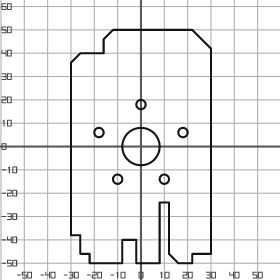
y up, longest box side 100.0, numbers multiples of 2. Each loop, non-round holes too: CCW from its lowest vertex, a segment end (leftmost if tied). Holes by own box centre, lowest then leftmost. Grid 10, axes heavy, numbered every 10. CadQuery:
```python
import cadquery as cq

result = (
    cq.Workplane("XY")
    .moveTo(-22.0, -50.0)
    .lineTo(-8.0, -50.0)
    .lineTo(-8.0, -40.0)
    .lineTo(-2.0, -40.0)
    .lineTo(-2.0, -50.0)
    .lineTo(8.0, -50.0)
    .lineTo(8.0, -24.0)
    .lineTo(12.0, -24.0)
    .lineTo(12.0, -46.0)
    .lineTo(16.0, -50.0)
    .lineTo(22.0, -50.0)
    .lineTo(22.0, -46.0)
    .lineTo(30.0, -46.0)
    .lineTo(30.0, 42.0)
    .lineTo(22.0, 50.0)
    .lineTo(-12.0, 50.0)
    .lineTo(-16.0, 46.0)
    .lineTo(-16.0, 40.0)
    .lineTo(-26.0, 40.0)
    .lineTo(-30.0, 36.0)
    .lineTo(-30.0, -38.0)
    .lineTo(-26.0, -38.0)
    .lineTo(-26.0, -46.0)
    .lineTo(-22.0, -46.0)
    .close()
    .moveTo(-10.0, -14.0)
    .circle(2.0)
    .moveTo(10.0, -14.0)
    .circle(2.0)
    .moveTo(0.0, 0.0)
    .circle(8.0)
    .moveTo(-18.0, 6.0)
    .circle(2.0)
    .moveTo(18.0, 6.0)
    .circle(2.0)
    .moveTo(0.0, 18.0)
    .circle(2.0)
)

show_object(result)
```